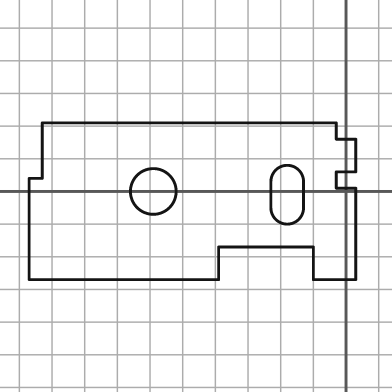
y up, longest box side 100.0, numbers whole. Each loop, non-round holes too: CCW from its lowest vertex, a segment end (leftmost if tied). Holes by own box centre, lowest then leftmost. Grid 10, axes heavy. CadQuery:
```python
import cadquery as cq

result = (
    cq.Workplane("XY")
    .moveTo(-97.0, -27.0)
    .lineTo(-39.0, -27.0)
    .lineTo(-39.0, -17.0)
    .lineTo(-10.0, -17.0)
    .lineTo(-10.0, -27.0)
    .lineTo(3.0, -27.0)
    .lineTo(3.0, 1.0)
    .lineTo(-3.0, 1.0)
    .lineTo(-3.0, 6.0)
    .lineTo(3.0, 6.0)
    .lineTo(3.0, 16.0)
    .lineTo(-3.0, 16.0)
    .lineTo(-3.0, 21.0)
    .lineTo(-93.0, 21.0)
    .lineTo(-93.0, 4.0)
    .lineTo(-97.0, 4.0)
    .close()
    .moveTo(-23.0, -5.0)
    .threePointArc((-18.0, -10.0), (-13.0, -5.0))
    .lineTo(-13.0, 3.0)
    .threePointArc((-18.0, 8.0), (-23.0, 3.0))
    .close()
    .moveTo(-59.0, 0.0)
    .circle(7.0)
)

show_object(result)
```